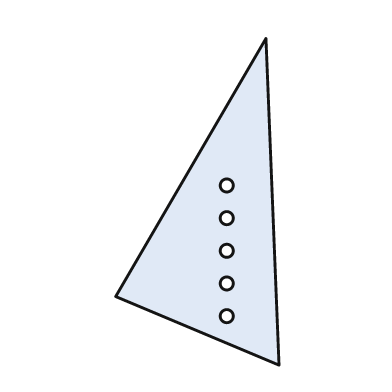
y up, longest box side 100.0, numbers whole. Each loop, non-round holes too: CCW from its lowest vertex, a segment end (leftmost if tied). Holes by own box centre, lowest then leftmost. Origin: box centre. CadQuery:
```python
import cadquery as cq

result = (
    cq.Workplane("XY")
    .moveTo(25.0, -50.0)
    .lineTo(21.0, 50.0)
    .lineTo(-25.0, -29.0)
    .close()
    .moveTo(9.0, -35.0)
    .circle(2.0)
    .moveTo(9.0, -25.0)
    .circle(2.0)
    .moveTo(9.0, -15.0)
    .circle(2.0)
    .moveTo(9.0, -5.0)
    .circle(2.0)
    .moveTo(9.0, 5.0)
    .circle(2.0)
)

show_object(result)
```